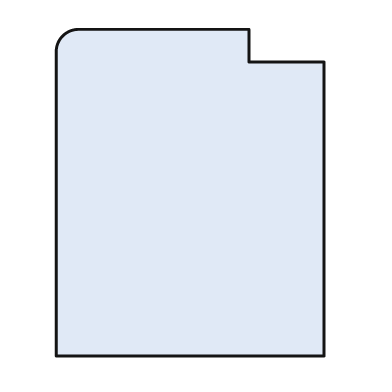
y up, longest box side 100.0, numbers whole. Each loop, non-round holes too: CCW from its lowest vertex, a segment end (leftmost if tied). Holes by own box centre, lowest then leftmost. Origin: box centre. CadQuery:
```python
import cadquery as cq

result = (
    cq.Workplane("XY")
    .moveTo(-41.0, -50.0)
    .lineTo(41.0, -50.0)
    .lineTo(41.0, 40.0)
    .lineTo(18.0, 40.0)
    .lineTo(18.0, 50.0)
    .lineTo(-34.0, 50.0)
    .threePointArc((-39.0, 48.0), (-41.0, 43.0))
    .close()
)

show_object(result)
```